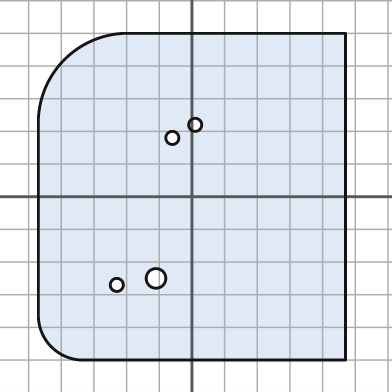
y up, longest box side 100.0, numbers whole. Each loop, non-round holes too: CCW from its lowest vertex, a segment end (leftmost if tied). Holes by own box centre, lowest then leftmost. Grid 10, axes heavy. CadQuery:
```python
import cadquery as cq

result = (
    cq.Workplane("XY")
    .moveTo(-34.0, -50.0)
    .lineTo(47.0, -50.0)
    .lineTo(47.0, 50.0)
    .lineTo(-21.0, 50.0)
    .threePointArc((-39.0, 42.0), (-47.0, 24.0))
    .lineTo(-47.0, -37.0)
    .threePointArc((-43.0, -46.0), (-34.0, -50.0))
    .close()
    .moveTo(-23.0, -27.0)
    .circle(2.0)
    .moveTo(-11.0, -25.0)
    .circle(3.0)
    .moveTo(-6.0, 18.0)
    .circle(2.0)
    .moveTo(1.0, 22.0)
    .circle(2.0)
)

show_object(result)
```